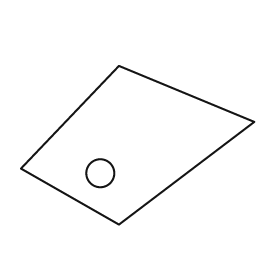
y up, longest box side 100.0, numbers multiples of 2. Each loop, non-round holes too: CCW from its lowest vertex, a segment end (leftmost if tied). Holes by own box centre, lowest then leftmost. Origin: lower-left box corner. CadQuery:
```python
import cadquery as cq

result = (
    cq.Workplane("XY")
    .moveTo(42.0, 0.0)
    .lineTo(100.0, 44.0)
    .lineTo(42.0, 68.0)
    .lineTo(0.0, 24.0)
    .close()
    .moveTo(34.0, 22.0)
    .circle(6.0)
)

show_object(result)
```